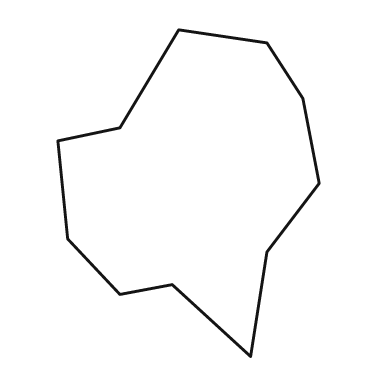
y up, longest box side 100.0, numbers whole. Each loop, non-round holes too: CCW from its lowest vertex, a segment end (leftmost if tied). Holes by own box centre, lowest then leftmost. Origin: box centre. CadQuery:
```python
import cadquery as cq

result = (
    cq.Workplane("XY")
    .moveTo(19.0, -50.0)
    .lineTo(24.0, -18.0)
    .lineTo(40.0, 3.0)
    .lineTo(35.0, 29.0)
    .lineTo(24.0, 46.0)
    .lineTo(-3.0, 50.0)
    .lineTo(-21.0, 20.0)
    .lineTo(-40.0, 16.0)
    .lineTo(-37.0, -14.0)
    .lineTo(-21.0, -31.0)
    .lineTo(-5.0, -28.0)
    .close()
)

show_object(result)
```